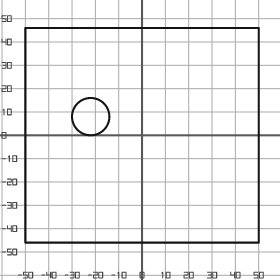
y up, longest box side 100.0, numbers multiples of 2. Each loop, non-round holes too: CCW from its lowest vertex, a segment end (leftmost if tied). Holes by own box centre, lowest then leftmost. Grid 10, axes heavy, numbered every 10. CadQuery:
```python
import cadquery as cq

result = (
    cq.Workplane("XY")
    .moveTo(-50.0, -46.0)
    .lineTo(50.0, -46.0)
    .lineTo(50.0, 46.0)
    .lineTo(-50.0, 46.0)
    .close()
    .moveTo(-22.0, 8.0)
    .circle(8.0)
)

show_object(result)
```